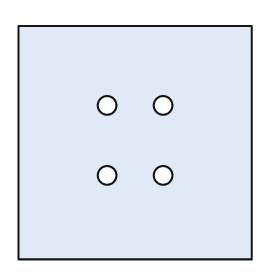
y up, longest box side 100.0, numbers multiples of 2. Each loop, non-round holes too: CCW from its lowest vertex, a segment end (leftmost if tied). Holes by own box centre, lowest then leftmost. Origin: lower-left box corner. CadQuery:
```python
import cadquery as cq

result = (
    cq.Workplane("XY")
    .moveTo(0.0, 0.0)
    .lineTo(100.0, 0.0)
    .lineTo(100.0, 100.0)
    .lineTo(0.0, 100.0)
    .close()
    .moveTo(38.0, 36.0)
    .circle(4.0)
    .moveTo(62.0, 36.0)
    .circle(4.0)
    .moveTo(38.0, 66.0)
    .circle(4.0)
    .moveTo(62.0, 66.0)
    .circle(4.0)
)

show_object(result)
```